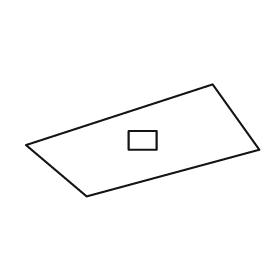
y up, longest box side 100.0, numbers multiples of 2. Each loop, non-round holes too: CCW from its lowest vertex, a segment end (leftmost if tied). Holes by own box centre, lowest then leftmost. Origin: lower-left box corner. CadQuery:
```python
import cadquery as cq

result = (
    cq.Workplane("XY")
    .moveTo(26.0, 0.0)
    .lineTo(100.0, 20.0)
    .lineTo(80.0, 48.0)
    .lineTo(0.0, 22.0)
    .close()
    .moveTo(44.0, 20.0)
    .lineTo(56.0, 20.0)
    .lineTo(56.0, 28.0)
    .lineTo(44.0, 28.0)
    .close()
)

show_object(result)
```